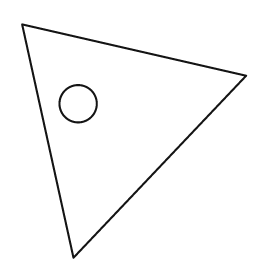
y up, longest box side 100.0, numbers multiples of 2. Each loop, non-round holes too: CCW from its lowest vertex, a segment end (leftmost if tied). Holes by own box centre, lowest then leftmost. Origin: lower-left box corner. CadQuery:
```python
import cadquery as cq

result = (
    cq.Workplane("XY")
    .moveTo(22.0, 0.0)
    .lineTo(96.0, 78.0)
    .lineTo(0.0, 100.0)
    .close()
    .moveTo(24.0, 66.0)
    .circle(8.0)
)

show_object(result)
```